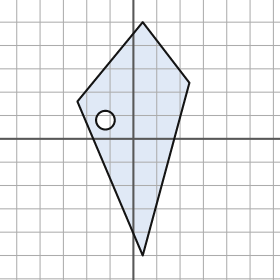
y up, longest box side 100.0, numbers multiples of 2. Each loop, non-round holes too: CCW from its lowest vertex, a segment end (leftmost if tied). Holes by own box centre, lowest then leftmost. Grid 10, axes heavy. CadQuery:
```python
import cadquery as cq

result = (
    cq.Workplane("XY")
    .moveTo(4.0, -50.0)
    .lineTo(24.0, 24.0)
    .lineTo(4.0, 50.0)
    .lineTo(-24.0, 16.0)
    .close()
    .moveTo(-12.0, 8.0)
    .circle(4.0)
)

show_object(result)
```